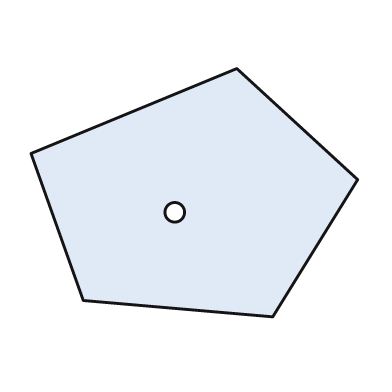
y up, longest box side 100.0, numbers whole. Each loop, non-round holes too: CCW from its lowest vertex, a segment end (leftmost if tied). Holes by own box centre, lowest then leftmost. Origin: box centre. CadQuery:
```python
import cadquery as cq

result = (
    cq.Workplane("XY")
    .moveTo(24.0, -38.0)
    .lineTo(50.0, 4.0)
    .lineTo(13.0, 38.0)
    .lineTo(-50.0, 12.0)
    .lineTo(-34.0, -33.0)
    .close()
    .moveTo(-6.0, -6.0)
    .circle(3.0)
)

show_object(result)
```